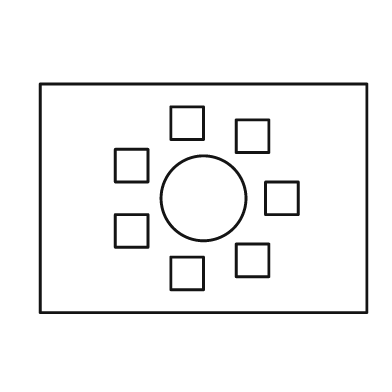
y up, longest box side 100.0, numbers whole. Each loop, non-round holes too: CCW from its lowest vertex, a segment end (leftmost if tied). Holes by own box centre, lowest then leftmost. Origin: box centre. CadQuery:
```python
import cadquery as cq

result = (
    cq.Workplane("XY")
    .moveTo(-50.0, -35.0)
    .lineTo(50.0, -35.0)
    .lineTo(50.0, 35.0)
    .lineTo(-50.0, 35.0)
    .close()
    .moveTo(-10.0, -28.0)
    .lineTo(0.0, -28.0)
    .lineTo(0.0, -18.0)
    .lineTo(-10.0, -18.0)
    .close()
    .moveTo(10.0, -24.0)
    .lineTo(20.0, -24.0)
    .lineTo(20.0, -14.0)
    .lineTo(10.0, -14.0)
    .close()
    .moveTo(-27.0, -15.0)
    .lineTo(-17.0, -15.0)
    .lineTo(-17.0, -5.0)
    .lineTo(-27.0, -5.0)
    .close()
    .moveTo(0.0, 0.0)
    .circle(13.0)
    .moveTo(19.0, -5.0)
    .lineTo(29.0, -5.0)
    .lineTo(29.0, 5.0)
    .lineTo(19.0, 5.0)
    .close()
    .moveTo(-27.0, 5.0)
    .lineTo(-17.0, 5.0)
    .lineTo(-17.0, 15.0)
    .lineTo(-27.0, 15.0)
    .close()
    .moveTo(10.0, 14.0)
    .lineTo(20.0, 14.0)
    .lineTo(20.0, 24.0)
    .lineTo(10.0, 24.0)
    .close()
    .moveTo(-10.0, 18.0)
    .lineTo(0.0, 18.0)
    .lineTo(0.0, 28.0)
    .lineTo(-10.0, 28.0)
    .close()
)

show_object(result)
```